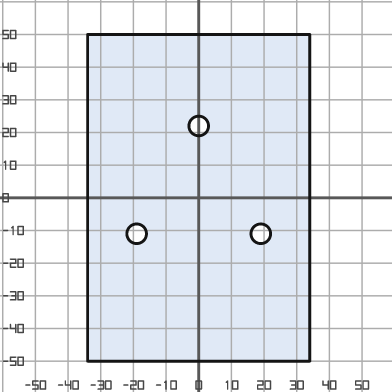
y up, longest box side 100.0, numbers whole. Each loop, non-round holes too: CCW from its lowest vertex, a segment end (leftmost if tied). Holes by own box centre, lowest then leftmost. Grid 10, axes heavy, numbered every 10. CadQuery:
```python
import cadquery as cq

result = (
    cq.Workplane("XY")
    .moveTo(-34.0, -50.0)
    .lineTo(34.0, -50.0)
    .lineTo(34.0, 50.0)
    .lineTo(-34.0, 50.0)
    .close()
    .moveTo(-19.0, -11.0)
    .circle(3.0)
    .moveTo(19.0, -11.0)
    .circle(3.0)
    .moveTo(0.0, 22.0)
    .circle(3.0)
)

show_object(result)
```